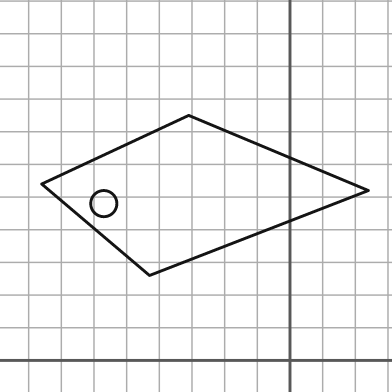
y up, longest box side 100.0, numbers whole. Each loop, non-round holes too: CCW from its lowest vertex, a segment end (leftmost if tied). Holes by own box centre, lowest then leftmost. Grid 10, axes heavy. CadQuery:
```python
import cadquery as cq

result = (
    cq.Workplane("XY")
    .moveTo(-43.0, 26.0)
    .lineTo(24.0, 52.0)
    .lineTo(-31.0, 75.0)
    .lineTo(-76.0, 54.0)
    .close()
    .moveTo(-57.0, 48.0)
    .circle(4.0)
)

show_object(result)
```